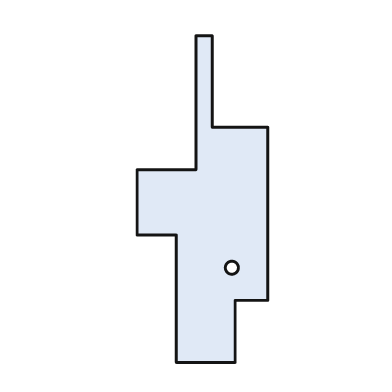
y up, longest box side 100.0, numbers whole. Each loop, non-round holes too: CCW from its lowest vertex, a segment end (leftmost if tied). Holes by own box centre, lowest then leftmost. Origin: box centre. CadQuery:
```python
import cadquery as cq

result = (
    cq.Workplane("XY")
    .moveTo(-8.0, -50.0)
    .lineTo(10.0, -50.0)
    .lineTo(10.0, -31.0)
    .lineTo(20.0, -31.0)
    .lineTo(20.0, 22.0)
    .lineTo(3.0, 22.0)
    .lineTo(3.0, 50.0)
    .lineTo(-2.0, 50.0)
    .lineTo(-2.0, 9.0)
    .lineTo(-20.0, 9.0)
    .lineTo(-20.0, -11.0)
    .lineTo(-8.0, -11.0)
    .close()
    .moveTo(9.0, -21.0)
    .circle(2.0)
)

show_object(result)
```